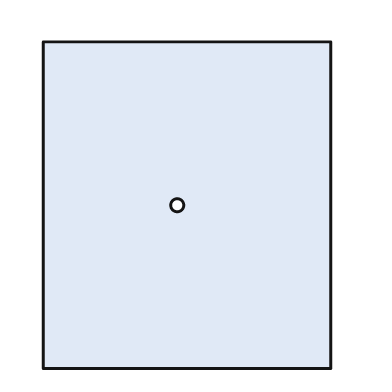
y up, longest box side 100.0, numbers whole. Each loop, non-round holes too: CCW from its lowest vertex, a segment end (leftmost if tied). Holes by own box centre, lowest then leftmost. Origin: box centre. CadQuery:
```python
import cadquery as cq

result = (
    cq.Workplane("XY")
    .moveTo(-44.0, -50.0)
    .lineTo(44.0, -50.0)
    .lineTo(44.0, 50.0)
    .lineTo(-44.0, 50.0)
    .close()
    .moveTo(-3.0, 0.0)
    .circle(2.0)
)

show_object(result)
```